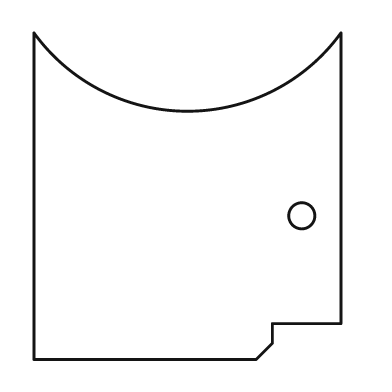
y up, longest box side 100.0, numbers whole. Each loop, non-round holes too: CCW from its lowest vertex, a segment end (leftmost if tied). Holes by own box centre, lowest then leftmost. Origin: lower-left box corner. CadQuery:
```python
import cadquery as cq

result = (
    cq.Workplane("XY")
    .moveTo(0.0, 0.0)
    .lineTo(68.0, 0.0)
    .lineTo(73.0, 5.0)
    .lineTo(73.0, 11.0)
    .lineTo(94.0, 11.0)
    .lineTo(94.0, 100.0)
    .threePointArc((47.0, 76.0), (0.0, 100.0))
    .close()
    .moveTo(82.0, 44.0)
    .circle(4.0)
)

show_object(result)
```